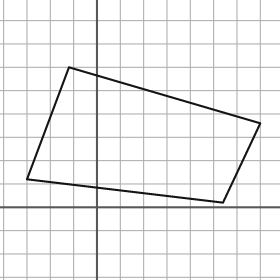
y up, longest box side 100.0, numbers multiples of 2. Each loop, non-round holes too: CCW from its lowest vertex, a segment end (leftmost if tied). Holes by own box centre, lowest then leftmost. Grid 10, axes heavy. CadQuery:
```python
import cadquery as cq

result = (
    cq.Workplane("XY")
    .moveTo(54.0, 2.0)
    .lineTo(70.0, 36.0)
    .lineTo(-12.0, 60.0)
    .lineTo(-30.0, 12.0)
    .close()
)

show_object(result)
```